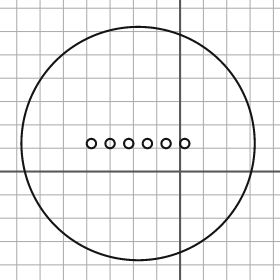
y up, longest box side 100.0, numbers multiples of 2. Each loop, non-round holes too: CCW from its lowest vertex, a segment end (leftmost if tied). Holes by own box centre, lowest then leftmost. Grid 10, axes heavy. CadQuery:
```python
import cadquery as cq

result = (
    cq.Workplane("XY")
    .moveTo(-18.0, 12.0)
    .circle(50.0)
    .moveTo(-38.0, 12.0)
    .circle(2.0)
    .moveTo(-30.0, 12.0)
    .circle(2.0)
    .moveTo(-22.0, 12.0)
    .circle(2.0)
    .moveTo(-14.0, 12.0)
    .circle(2.0)
    .moveTo(-6.0, 12.0)
    .circle(2.0)
    .moveTo(2.0, 12.0)
    .circle(2.0)
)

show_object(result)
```